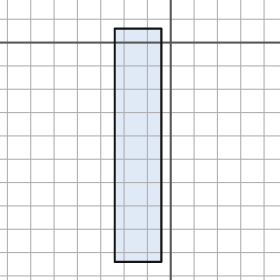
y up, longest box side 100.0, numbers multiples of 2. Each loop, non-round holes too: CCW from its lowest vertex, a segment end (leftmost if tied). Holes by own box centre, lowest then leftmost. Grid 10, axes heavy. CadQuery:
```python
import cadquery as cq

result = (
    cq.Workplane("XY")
    .moveTo(-24.0, -94.0)
    .lineTo(-4.0, -94.0)
    .lineTo(-4.0, 6.0)
    .lineTo(-24.0, 6.0)
    .close()
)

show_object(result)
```